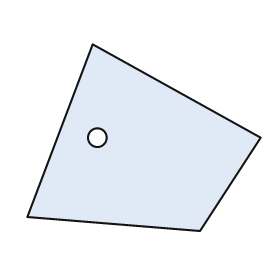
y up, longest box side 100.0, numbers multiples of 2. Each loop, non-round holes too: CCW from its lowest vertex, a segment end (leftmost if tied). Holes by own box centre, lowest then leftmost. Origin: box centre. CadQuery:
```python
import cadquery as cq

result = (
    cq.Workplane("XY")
    .moveTo(24.0, -40.0)
    .lineTo(50.0, 0.0)
    .lineTo(-22.0, 40.0)
    .lineTo(-50.0, -34.0)
    .close()
    .moveTo(-20.0, 0.0)
    .circle(4.0)
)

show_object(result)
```